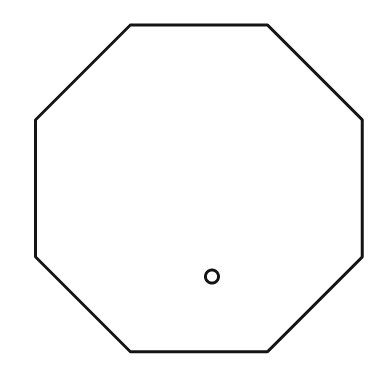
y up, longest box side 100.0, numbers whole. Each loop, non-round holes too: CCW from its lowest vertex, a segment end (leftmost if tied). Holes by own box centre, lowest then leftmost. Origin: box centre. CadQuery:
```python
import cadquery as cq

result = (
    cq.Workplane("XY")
    .moveTo(-21.0, -50.0)
    .lineTo(21.0, -50.0)
    .lineTo(50.0, -21.0)
    .lineTo(50.0, 21.0)
    .lineTo(21.0, 50.0)
    .lineTo(-21.0, 50.0)
    .lineTo(-50.0, 21.0)
    .lineTo(-50.0, -21.0)
    .close()
    .moveTo(4.0, -27.0)
    .circle(2.0)
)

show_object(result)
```